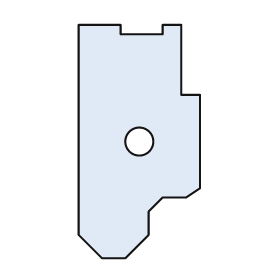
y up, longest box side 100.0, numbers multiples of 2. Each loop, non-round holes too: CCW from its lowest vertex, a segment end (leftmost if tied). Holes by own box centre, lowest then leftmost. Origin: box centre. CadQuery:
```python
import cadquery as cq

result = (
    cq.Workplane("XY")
    .moveTo(-16.0, -50.0)
    .lineTo(-6.0, -50.0)
    .lineTo(4.0, -40.0)
    .lineTo(4.0, -30.0)
    .lineTo(10.0, -24.0)
    .lineTo(20.0, -24.0)
    .lineTo(26.0, -20.0)
    .lineTo(26.0, 20.0)
    .lineTo(18.0, 20.0)
    .lineTo(18.0, 50.0)
    .lineTo(10.0, 50.0)
    .lineTo(10.0, 46.0)
    .lineTo(-8.0, 46.0)
    .lineTo(-8.0, 50.0)
    .lineTo(-26.0, 50.0)
    .lineTo(-26.0, -40.0)
    .close()
    .moveTo(0.0, 0.0)
    .circle(6.0)
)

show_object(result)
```